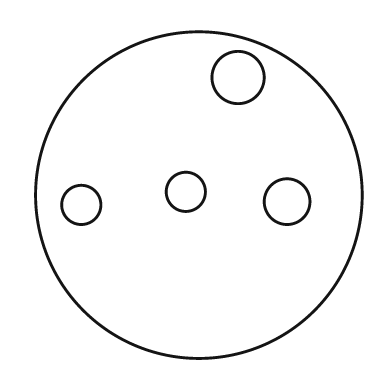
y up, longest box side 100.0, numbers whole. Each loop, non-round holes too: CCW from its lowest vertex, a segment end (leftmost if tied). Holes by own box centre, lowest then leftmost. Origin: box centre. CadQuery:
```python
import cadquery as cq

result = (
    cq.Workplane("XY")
    .moveTo(0.0, 0.0)
    .circle(50.0)
    .moveTo(-36.0, -3.0)
    .circle(6.0)
    .moveTo(27.0, -2.0)
    .circle(7.0)
    .moveTo(-4.0, 1.0)
    .circle(6.0)
    .moveTo(12.0, 36.0)
    .circle(8.0)
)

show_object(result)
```